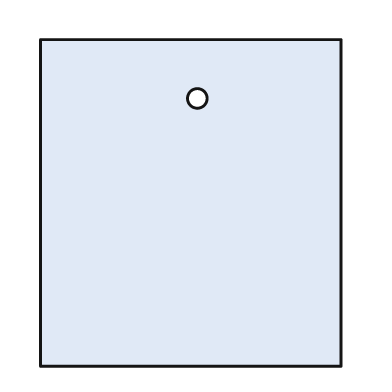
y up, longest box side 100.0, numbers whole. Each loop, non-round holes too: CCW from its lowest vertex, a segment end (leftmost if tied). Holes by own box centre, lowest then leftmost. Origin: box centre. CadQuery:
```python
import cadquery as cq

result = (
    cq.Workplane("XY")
    .moveTo(-46.0, -50.0)
    .lineTo(46.0, -50.0)
    .lineTo(46.0, 50.0)
    .lineTo(-46.0, 50.0)
    .close()
    .moveTo(2.0, 32.0)
    .circle(3.0)
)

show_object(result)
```